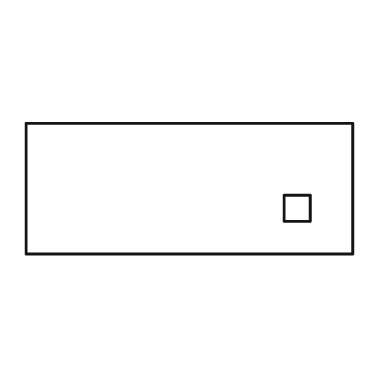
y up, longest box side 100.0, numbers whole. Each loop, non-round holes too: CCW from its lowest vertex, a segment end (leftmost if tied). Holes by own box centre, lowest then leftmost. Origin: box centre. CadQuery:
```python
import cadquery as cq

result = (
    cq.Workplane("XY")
    .moveTo(-50.0, -20.0)
    .lineTo(50.0, -20.0)
    .lineTo(50.0, 20.0)
    .lineTo(-50.0, 20.0)
    .close()
    .moveTo(29.0, -10.0)
    .lineTo(37.0, -10.0)
    .lineTo(37.0, -2.0)
    .lineTo(29.0, -2.0)
    .close()
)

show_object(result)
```